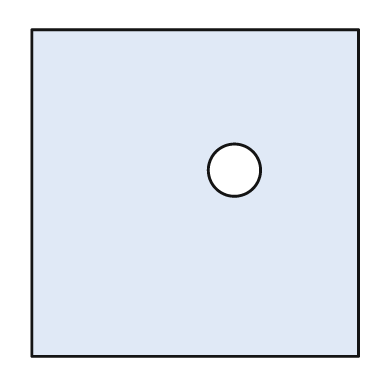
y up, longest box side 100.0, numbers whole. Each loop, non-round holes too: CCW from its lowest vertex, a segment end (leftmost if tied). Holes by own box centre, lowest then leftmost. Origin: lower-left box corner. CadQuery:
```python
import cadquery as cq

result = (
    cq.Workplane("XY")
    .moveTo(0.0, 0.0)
    .lineTo(100.0, 0.0)
    .lineTo(100.0, 100.0)
    .lineTo(0.0, 100.0)
    .close()
    .moveTo(62.0, 57.0)
    .circle(8.0)
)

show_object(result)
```